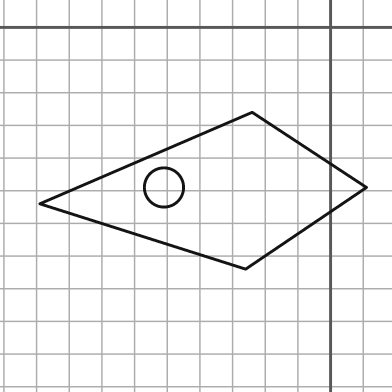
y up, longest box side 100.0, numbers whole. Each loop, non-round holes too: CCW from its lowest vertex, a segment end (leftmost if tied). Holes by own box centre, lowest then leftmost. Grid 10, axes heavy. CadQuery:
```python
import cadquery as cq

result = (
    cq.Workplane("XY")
    .moveTo(-26.0, -74.0)
    .lineTo(11.0, -49.0)
    .lineTo(-24.0, -26.0)
    .lineTo(-89.0, -54.0)
    .close()
    .moveTo(-51.0, -49.0)
    .circle(6.0)
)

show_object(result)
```